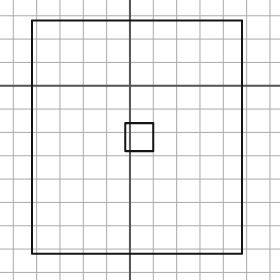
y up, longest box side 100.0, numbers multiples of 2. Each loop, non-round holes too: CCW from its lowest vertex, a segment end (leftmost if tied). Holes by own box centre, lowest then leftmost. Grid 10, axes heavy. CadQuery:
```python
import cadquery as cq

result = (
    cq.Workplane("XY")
    .moveTo(-42.0, -72.0)
    .lineTo(48.0, -72.0)
    .lineTo(48.0, 28.0)
    .lineTo(-42.0, 28.0)
    .close()
    .moveTo(-2.0, -28.0)
    .lineTo(10.0, -28.0)
    .lineTo(10.0, -16.0)
    .lineTo(-2.0, -16.0)
    .close()
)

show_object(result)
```